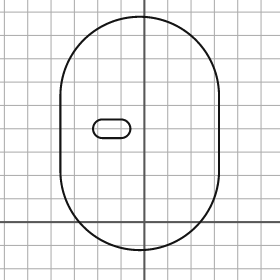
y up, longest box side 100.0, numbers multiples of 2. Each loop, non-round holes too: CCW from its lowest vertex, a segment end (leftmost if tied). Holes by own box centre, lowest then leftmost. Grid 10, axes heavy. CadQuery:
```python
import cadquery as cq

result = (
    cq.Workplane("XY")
    .moveTo(-36.0, 22.0)
    .threePointArc((-2.0, -12.0), (32.0, 22.0))
    .lineTo(32.0, 54.0)
    .threePointArc((-2.0, 88.0), (-36.0, 54.0))
    .close()
    .moveTo(-18.0, 36.0)
    .lineTo(-10.0, 36.0)
    .threePointArc((-6.0, 40.0), (-10.0, 44.0))
    .lineTo(-18.0, 44.0)
    .threePointArc((-22.0, 40.0), (-18.0, 36.0))
    .close()
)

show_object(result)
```